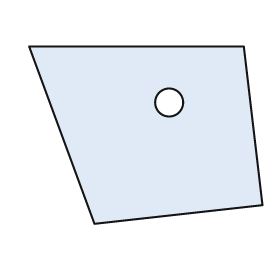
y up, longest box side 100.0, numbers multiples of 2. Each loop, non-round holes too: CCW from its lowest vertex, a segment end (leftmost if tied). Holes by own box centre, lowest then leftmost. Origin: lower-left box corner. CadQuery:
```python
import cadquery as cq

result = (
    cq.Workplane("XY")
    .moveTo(28.0, 0.0)
    .lineTo(100.0, 8.0)
    .lineTo(92.0, 76.0)
    .lineTo(0.0, 76.0)
    .close()
    .moveTo(60.0, 52.0)
    .circle(6.0)
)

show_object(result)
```